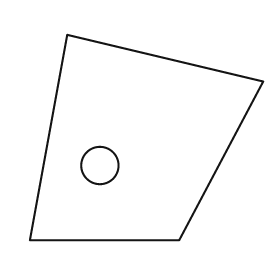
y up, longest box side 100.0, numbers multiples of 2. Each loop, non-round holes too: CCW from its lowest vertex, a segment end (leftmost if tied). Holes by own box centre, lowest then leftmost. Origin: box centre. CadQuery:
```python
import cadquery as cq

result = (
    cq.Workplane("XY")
    .moveTo(-50.0, -44.0)
    .lineTo(14.0, -44.0)
    .lineTo(50.0, 24.0)
    .lineTo(-34.0, 44.0)
    .close()
    .moveTo(-20.0, -12.0)
    .circle(8.0)
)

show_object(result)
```